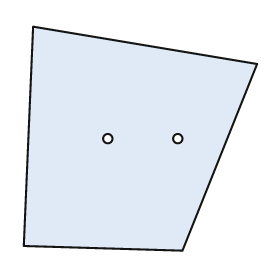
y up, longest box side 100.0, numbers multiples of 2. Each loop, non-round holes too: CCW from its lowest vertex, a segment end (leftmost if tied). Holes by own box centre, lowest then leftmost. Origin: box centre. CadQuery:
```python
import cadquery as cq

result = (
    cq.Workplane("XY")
    .moveTo(18.0, -48.0)
    .lineTo(50.0, 32.0)
    .lineTo(-46.0, 48.0)
    .lineTo(-50.0, -46.0)
    .close()
    .moveTo(-14.0, 0.0)
    .circle(2.0)
    .moveTo(16.0, 0.0)
    .circle(2.0)
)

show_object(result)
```